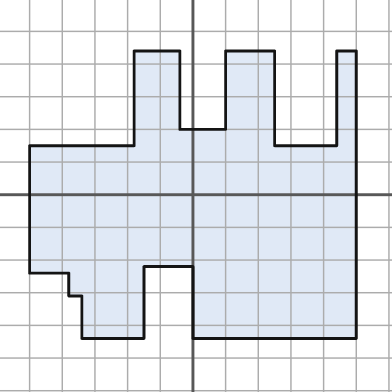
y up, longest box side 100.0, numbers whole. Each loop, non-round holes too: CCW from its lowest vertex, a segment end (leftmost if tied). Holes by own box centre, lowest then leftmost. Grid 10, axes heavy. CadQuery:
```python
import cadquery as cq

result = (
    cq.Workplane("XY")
    .moveTo(-34.0, -44.0)
    .lineTo(-15.0, -44.0)
    .lineTo(-15.0, -22.0)
    .lineTo(0.0, -22.0)
    .lineTo(0.0, -44.0)
    .lineTo(50.0, -44.0)
    .lineTo(50.0, 44.0)
    .lineTo(44.0, 44.0)
    .lineTo(44.0, 15.0)
    .lineTo(25.0, 15.0)
    .lineTo(25.0, 44.0)
    .lineTo(10.0, 44.0)
    .lineTo(10.0, 20.0)
    .lineTo(-4.0, 20.0)
    .lineTo(-4.0, 44.0)
    .lineTo(-18.0, 44.0)
    .lineTo(-18.0, 15.0)
    .lineTo(-50.0, 15.0)
    .lineTo(-50.0, -24.0)
    .lineTo(-38.0, -24.0)
    .lineTo(-38.0, -31.0)
    .lineTo(-34.0, -31.0)
    .close()
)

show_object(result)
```